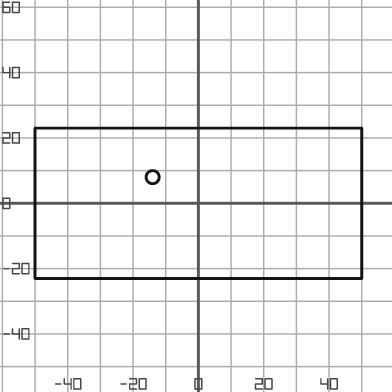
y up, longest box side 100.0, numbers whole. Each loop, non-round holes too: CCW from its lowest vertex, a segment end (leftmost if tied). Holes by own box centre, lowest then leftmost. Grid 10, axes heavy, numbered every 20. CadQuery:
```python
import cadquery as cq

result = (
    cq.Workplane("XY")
    .moveTo(-50.0, -23.0)
    .lineTo(50.0, -23.0)
    .lineTo(50.0, 23.0)
    .lineTo(-50.0, 23.0)
    .close()
    .moveTo(-14.0, 8.0)
    .circle(2.0)
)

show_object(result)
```